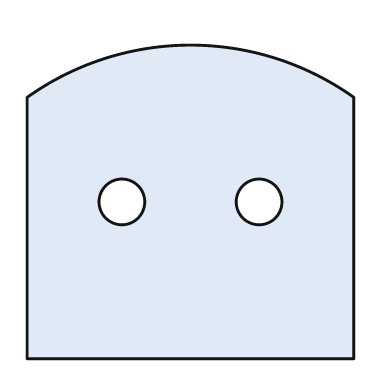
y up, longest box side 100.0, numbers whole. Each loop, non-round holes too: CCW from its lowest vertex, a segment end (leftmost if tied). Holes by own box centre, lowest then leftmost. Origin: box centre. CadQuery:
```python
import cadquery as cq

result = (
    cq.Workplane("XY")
    .moveTo(-50.0, -48.0)
    .lineTo(50.0, -48.0)
    .lineTo(50.0, 32.0)
    .threePointArc((0.0, 48.0), (-50.0, 32.0))
    .close()
    .moveTo(-21.0, 0.0)
    .circle(7.0)
    .moveTo(21.0, 0.0)
    .circle(7.0)
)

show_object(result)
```